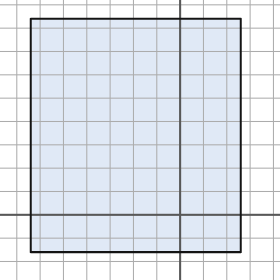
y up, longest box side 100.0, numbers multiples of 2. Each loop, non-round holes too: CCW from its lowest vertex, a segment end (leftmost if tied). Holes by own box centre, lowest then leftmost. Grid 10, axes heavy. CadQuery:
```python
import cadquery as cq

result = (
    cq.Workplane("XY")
    .moveTo(-64.0, -16.0)
    .lineTo(26.0, -16.0)
    .lineTo(26.0, 84.0)
    .lineTo(-64.0, 84.0)
    .close()
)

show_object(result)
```